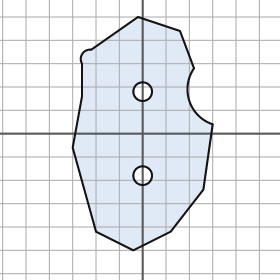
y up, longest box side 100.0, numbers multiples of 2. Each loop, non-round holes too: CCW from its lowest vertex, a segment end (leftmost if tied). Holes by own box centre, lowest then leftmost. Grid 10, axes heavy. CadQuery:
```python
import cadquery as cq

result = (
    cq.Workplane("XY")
    .moveTo(-4.0, -50.0)
    .lineTo(12.0, -42.0)
    .lineTo(26.0, -24.0)
    .lineTo(30.0, 4.0)
    .threePointArc((20.0, 14.0), (22.0, 28.0))
    .lineTo(16.0, 44.0)
    .lineTo(-2.0, 50.0)
    .lineTo(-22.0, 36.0)
    .threePointArc((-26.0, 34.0), (-26.0, 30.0))
    .lineTo(-26.0, 16.0)
    .lineTo(-30.0, -6.0)
    .lineTo(-20.0, -42.0)
    .close()
    .moveTo(0.0, -18.0)
    .circle(4.0)
    .moveTo(0.0, 18.0)
    .circle(4.0)
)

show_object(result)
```